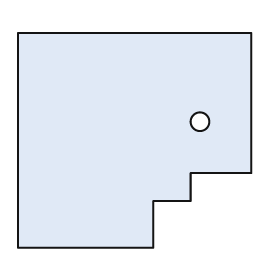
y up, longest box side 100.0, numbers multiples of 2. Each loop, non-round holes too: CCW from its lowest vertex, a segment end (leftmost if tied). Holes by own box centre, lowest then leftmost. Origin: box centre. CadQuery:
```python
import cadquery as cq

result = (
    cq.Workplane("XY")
    .moveTo(-50.0, -46.0)
    .lineTo(8.0, -46.0)
    .lineTo(8.0, -26.0)
    .lineTo(24.0, -26.0)
    .lineTo(24.0, -14.0)
    .lineTo(50.0, -14.0)
    .lineTo(50.0, 46.0)
    .lineTo(-50.0, 46.0)
    .close()
    .moveTo(28.0, 8.0)
    .circle(4.0)
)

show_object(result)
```